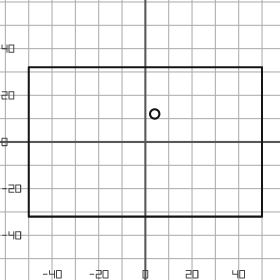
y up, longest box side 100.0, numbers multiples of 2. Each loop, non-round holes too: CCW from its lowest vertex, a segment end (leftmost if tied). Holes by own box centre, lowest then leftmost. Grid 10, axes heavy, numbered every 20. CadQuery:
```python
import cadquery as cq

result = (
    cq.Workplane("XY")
    .moveTo(-50.0, -32.0)
    .lineTo(50.0, -32.0)
    .lineTo(50.0, 32.0)
    .lineTo(-50.0, 32.0)
    .close()
    .moveTo(4.0, 12.0)
    .circle(2.0)
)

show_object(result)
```